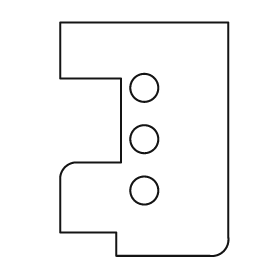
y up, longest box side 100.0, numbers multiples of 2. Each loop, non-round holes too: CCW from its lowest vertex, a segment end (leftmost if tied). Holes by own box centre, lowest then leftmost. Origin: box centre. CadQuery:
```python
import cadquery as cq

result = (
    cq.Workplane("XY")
    .moveTo(-12.0, -50.0)
    .lineTo(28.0, -50.0)
    .threePointArc((34.0, -48.0), (36.0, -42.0))
    .lineTo(36.0, 50.0)
    .lineTo(-36.0, 50.0)
    .lineTo(-36.0, 26.0)
    .lineTo(-10.0, 26.0)
    .lineTo(-10.0, -10.0)
    .lineTo(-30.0, -10.0)
    .threePointArc((-34.0, -12.0), (-36.0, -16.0))
    .lineTo(-36.0, -40.0)
    .lineTo(-12.0, -40.0)
    .close()
    .moveTo(0.0, -22.0)
    .circle(6.0)
    .moveTo(0.0, 0.0)
    .circle(6.0)
    .moveTo(0.0, 22.0)
    .circle(6.0)
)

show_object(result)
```